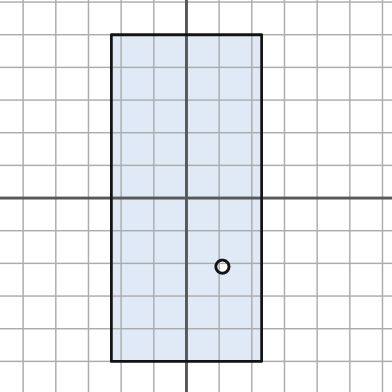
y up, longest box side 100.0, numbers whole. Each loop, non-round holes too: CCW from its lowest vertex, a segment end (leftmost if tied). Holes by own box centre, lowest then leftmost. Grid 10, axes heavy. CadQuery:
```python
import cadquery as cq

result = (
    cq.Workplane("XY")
    .moveTo(-23.0, -50.0)
    .lineTo(23.0, -50.0)
    .lineTo(23.0, 50.0)
    .lineTo(-23.0, 50.0)
    .close()
    .moveTo(11.0, -21.0)
    .circle(2.0)
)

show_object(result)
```